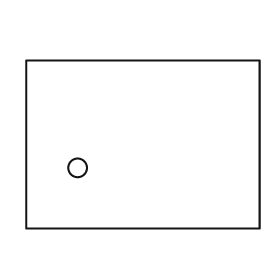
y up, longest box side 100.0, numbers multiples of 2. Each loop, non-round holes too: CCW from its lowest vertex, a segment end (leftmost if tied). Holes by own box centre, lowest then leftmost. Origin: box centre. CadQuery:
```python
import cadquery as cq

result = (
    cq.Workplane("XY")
    .moveTo(-50.0, -36.0)
    .lineTo(50.0, -36.0)
    .lineTo(50.0, 36.0)
    .lineTo(-50.0, 36.0)
    .close()
    .moveTo(-28.0, -10.0)
    .circle(4.0)
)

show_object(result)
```